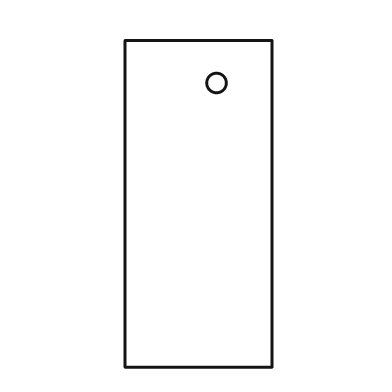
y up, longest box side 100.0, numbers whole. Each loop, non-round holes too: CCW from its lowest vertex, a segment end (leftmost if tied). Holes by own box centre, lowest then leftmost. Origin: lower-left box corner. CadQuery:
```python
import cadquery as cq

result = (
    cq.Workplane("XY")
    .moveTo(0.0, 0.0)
    .lineTo(45.0, 0.0)
    .lineTo(45.0, 100.0)
    .lineTo(0.0, 100.0)
    .close()
    .moveTo(28.0, 87.0)
    .circle(3.0)
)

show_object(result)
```